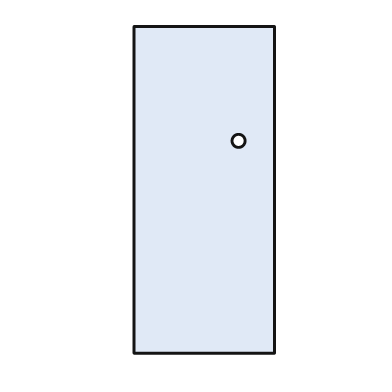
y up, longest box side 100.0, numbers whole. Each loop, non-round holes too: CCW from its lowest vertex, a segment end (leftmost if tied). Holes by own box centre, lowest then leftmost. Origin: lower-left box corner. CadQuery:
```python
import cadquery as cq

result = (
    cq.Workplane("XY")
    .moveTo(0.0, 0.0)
    .lineTo(43.0, 0.0)
    .lineTo(43.0, 100.0)
    .lineTo(0.0, 100.0)
    .close()
    .moveTo(32.0, 65.0)
    .circle(2.0)
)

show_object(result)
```